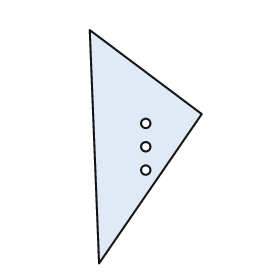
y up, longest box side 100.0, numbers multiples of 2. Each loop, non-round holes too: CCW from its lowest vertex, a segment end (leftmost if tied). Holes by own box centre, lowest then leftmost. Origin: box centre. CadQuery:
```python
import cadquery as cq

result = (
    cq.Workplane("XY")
    .moveTo(-20.0, -50.0)
    .lineTo(24.0, 14.0)
    .lineTo(-24.0, 50.0)
    .close()
    .moveTo(0.0, -10.0)
    .circle(2.0)
    .moveTo(0.0, 0.0)
    .circle(2.0)
    .moveTo(0.0, 10.0)
    .circle(2.0)
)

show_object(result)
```